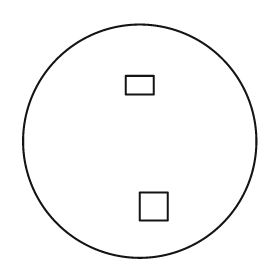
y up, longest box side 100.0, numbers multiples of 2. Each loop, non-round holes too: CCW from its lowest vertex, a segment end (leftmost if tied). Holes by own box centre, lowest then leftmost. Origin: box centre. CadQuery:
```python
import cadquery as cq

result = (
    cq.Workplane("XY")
    .moveTo(0.0, 0.0)
    .circle(50.0)
    .moveTo(0.0, -34.0)
    .lineTo(12.0, -34.0)
    .lineTo(12.0, -22.0)
    .lineTo(0.0, -22.0)
    .close()
    .moveTo(-6.0, 20.0)
    .lineTo(6.0, 20.0)
    .lineTo(6.0, 28.0)
    .lineTo(-6.0, 28.0)
    .close()
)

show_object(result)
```